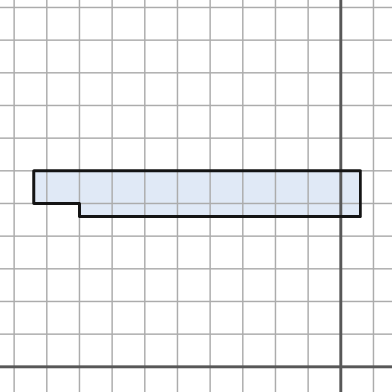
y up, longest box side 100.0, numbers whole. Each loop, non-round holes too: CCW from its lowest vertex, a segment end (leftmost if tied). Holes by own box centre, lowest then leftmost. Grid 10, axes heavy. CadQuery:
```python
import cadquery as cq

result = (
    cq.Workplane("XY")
    .moveTo(-80.0, 46.0)
    .lineTo(6.0, 46.0)
    .lineTo(6.0, 60.0)
    .lineTo(-94.0, 60.0)
    .lineTo(-94.0, 50.0)
    .lineTo(-80.0, 50.0)
    .close()
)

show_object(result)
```